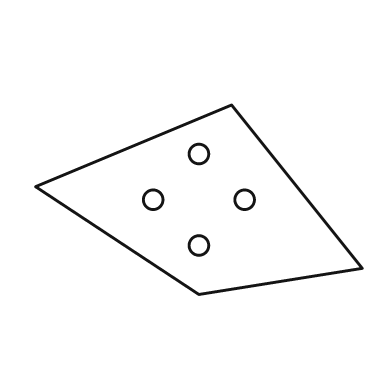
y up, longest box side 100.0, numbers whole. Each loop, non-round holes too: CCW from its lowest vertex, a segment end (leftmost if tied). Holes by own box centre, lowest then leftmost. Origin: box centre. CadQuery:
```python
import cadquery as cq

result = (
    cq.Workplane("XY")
    .moveTo(0.0, -29.0)
    .lineTo(50.0, -21.0)
    .lineTo(10.0, 29.0)
    .lineTo(-50.0, 4.0)
    .close()
    .moveTo(0.0, -14.0)
    .circle(3.0)
    .moveTo(-14.0, 0.0)
    .circle(3.0)
    .moveTo(14.0, 0.0)
    .circle(3.0)
    .moveTo(0.0, 14.0)
    .circle(3.0)
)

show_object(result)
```